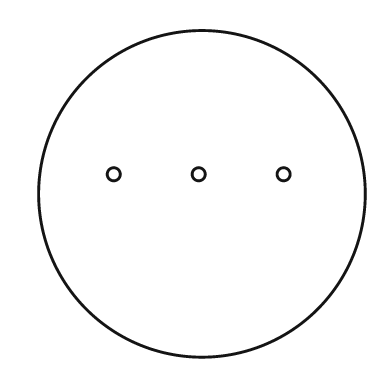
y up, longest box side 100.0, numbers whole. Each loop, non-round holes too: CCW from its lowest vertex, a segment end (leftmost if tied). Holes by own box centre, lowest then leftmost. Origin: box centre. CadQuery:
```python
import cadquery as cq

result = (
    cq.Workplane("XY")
    .moveTo(0.0, 0.0)
    .circle(50.0)
    .moveTo(-27.0, 6.0)
    .circle(2.0)
    .moveTo(-1.0, 6.0)
    .circle(2.0)
    .moveTo(25.0, 6.0)
    .circle(2.0)
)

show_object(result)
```